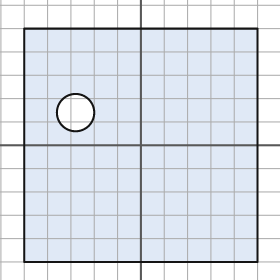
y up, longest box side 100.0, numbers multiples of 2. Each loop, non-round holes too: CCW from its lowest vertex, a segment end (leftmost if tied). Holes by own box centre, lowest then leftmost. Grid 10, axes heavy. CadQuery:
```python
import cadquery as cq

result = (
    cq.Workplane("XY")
    .moveTo(-50.0, -50.0)
    .lineTo(50.0, -50.0)
    .lineTo(50.0, 50.0)
    .lineTo(-50.0, 50.0)
    .close()
    .moveTo(-28.0, 14.0)
    .circle(8.0)
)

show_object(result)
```